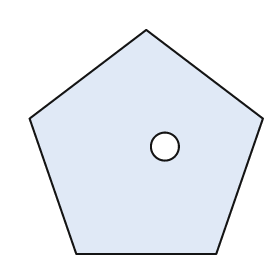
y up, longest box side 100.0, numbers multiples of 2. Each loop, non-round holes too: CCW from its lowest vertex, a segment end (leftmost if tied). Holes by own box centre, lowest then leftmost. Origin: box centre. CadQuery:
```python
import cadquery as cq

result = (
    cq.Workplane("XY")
    .moveTo(-30.0, -48.0)
    .lineTo(30.0, -48.0)
    .lineTo(50.0, 10.0)
    .lineTo(0.0, 48.0)
    .lineTo(-50.0, 10.0)
    .close()
    .moveTo(8.0, -2.0)
    .circle(6.0)
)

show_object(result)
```